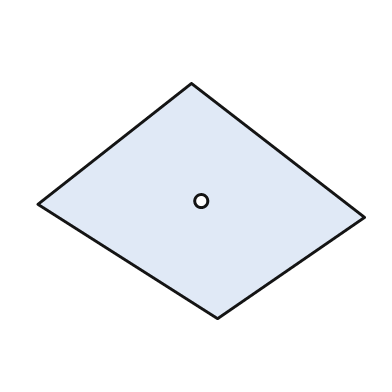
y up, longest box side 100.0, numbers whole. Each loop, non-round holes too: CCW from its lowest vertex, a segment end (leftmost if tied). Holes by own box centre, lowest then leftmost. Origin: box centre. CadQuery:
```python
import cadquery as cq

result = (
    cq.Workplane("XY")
    .moveTo(5.0, -36.0)
    .lineTo(50.0, -5.0)
    .lineTo(-3.0, 36.0)
    .lineTo(-50.0, -1.0)
    .close()
    .moveTo(0.0, 0.0)
    .circle(2.0)
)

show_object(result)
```